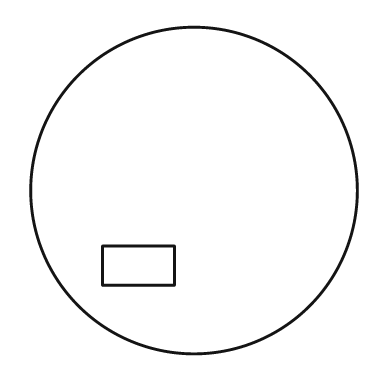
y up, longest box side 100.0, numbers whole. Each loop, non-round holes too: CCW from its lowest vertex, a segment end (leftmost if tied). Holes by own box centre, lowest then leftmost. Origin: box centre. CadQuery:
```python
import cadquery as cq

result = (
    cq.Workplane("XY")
    .moveTo(0.0, 0.0)
    .circle(50.0)
    .moveTo(-28.0, -29.0)
    .lineTo(-6.0, -29.0)
    .lineTo(-6.0, -17.0)
    .lineTo(-28.0, -17.0)
    .close()
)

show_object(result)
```